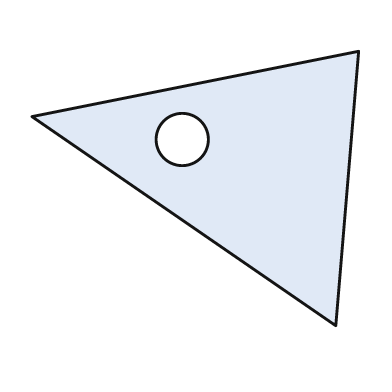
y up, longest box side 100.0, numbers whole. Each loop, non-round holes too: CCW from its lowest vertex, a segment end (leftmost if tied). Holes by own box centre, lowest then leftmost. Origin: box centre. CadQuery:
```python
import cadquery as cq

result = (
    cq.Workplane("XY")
    .moveTo(43.0, -42.0)
    .lineTo(50.0, 42.0)
    .lineTo(-50.0, 22.0)
    .close()
    .moveTo(-4.0, 15.0)
    .circle(8.0)
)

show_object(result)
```